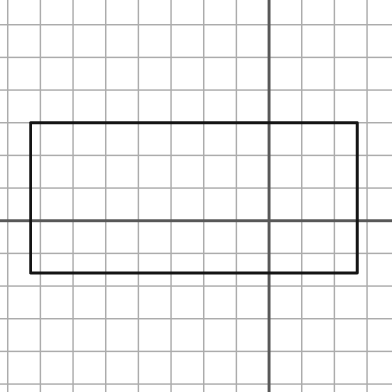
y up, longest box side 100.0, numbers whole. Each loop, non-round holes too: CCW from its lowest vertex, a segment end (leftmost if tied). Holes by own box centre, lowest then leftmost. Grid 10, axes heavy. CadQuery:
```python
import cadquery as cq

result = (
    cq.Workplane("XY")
    .moveTo(-73.0, -16.0)
    .lineTo(27.0, -16.0)
    .lineTo(27.0, 30.0)
    .lineTo(-73.0, 30.0)
    .close()
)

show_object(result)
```